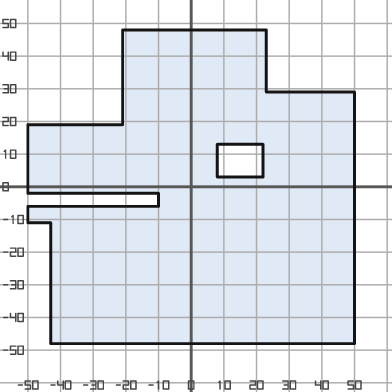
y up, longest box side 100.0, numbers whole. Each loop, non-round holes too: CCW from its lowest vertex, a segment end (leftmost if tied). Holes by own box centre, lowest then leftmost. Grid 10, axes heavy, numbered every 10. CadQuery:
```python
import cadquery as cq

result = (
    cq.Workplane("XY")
    .moveTo(-43.0, -48.0)
    .lineTo(50.0, -48.0)
    .lineTo(50.0, 29.0)
    .lineTo(23.0, 29.0)
    .lineTo(23.0, 48.0)
    .lineTo(-21.0, 48.0)
    .lineTo(-21.0, 19.0)
    .lineTo(-50.0, 19.0)
    .lineTo(-50.0, -2.0)
    .lineTo(-10.0, -2.0)
    .lineTo(-10.0, -6.0)
    .lineTo(-50.0, -6.0)
    .lineTo(-50.0, -11.0)
    .lineTo(-43.0, -11.0)
    .close()
    .moveTo(8.0, 3.0)
    .lineTo(22.0, 3.0)
    .lineTo(22.0, 13.0)
    .lineTo(8.0, 13.0)
    .close()
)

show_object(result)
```